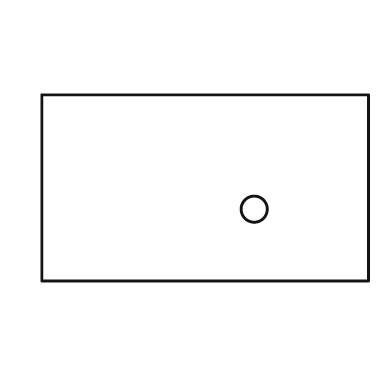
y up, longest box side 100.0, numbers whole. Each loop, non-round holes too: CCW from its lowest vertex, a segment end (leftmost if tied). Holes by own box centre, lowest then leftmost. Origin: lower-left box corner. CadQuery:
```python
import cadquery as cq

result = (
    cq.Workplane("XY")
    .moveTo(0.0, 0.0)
    .lineTo(100.0, 0.0)
    .lineTo(100.0, 57.0)
    .lineTo(0.0, 57.0)
    .close()
    .moveTo(65.0, 22.0)
    .circle(4.0)
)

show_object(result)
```